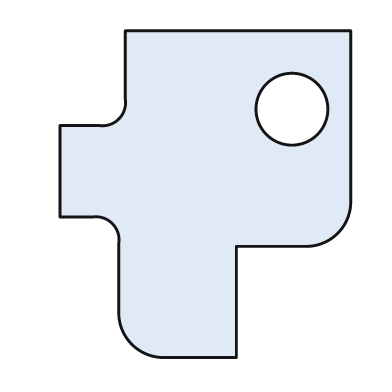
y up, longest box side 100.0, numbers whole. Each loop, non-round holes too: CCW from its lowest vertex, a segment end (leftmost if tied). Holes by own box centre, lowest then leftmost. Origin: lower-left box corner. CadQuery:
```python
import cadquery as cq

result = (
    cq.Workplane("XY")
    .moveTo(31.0, 0.0)
    .lineTo(54.0, 0.0)
    .lineTo(54.0, 34.0)
    .lineTo(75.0, 34.0)
    .threePointArc((85.0, 38.0), (89.0, 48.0))
    .lineTo(89.0, 100.0)
    .lineTo(20.0, 100.0)
    .lineTo(20.0, 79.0)
    .threePointArc((18.0, 73.0), (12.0, 71.0))
    .lineTo(0.0, 71.0)
    .lineTo(0.0, 43.0)
    .lineTo(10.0, 43.0)
    .threePointArc((16.0, 41.0), (18.0, 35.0))
    .lineTo(18.0, 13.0)
    .threePointArc((22.0, 4.0), (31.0, 0.0))
    .close()
    .moveTo(71.0, 76.0)
    .circle(11.0)
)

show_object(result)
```